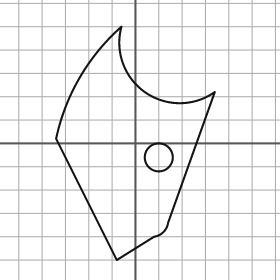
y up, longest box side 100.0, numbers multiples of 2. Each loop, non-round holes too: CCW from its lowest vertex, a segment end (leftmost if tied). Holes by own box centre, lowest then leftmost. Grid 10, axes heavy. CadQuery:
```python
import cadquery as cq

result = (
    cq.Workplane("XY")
    .moveTo(-8.0, -50.0)
    .lineTo(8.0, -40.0)
    .threePointArc((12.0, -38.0), (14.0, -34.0))
    .lineTo(34.0, 22.0)
    .threePointArc((4.0, 22.0), (-6.0, 50.0))
    .threePointArc((-24.0, 28.0), (-34.0, 2.0))
    .close()
    .moveTo(10.0, -6.0)
    .circle(6.0)
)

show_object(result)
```